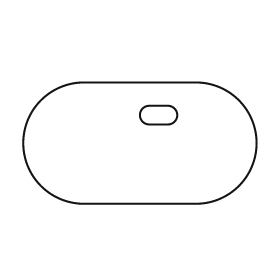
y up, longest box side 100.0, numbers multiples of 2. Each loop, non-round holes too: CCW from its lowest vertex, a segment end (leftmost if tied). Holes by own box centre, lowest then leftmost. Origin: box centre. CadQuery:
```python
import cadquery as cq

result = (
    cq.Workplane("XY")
    .moveTo(-24.0, -26.0)
    .lineTo(24.0, -26.0)
    .threePointArc((50.0, 0.0), (24.0, 26.0))
    .lineTo(-24.0, 26.0)
    .threePointArc((-50.0, 0.0), (-24.0, -26.0))
    .close()
    .moveTo(4.0, 8.0)
    .lineTo(12.0, 8.0)
    .threePointArc((16.0, 12.0), (12.0, 16.0))
    .lineTo(4.0, 16.0)
    .threePointArc((0.0, 12.0), (4.0, 8.0))
    .close()
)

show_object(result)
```